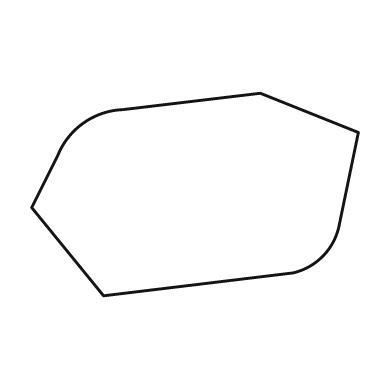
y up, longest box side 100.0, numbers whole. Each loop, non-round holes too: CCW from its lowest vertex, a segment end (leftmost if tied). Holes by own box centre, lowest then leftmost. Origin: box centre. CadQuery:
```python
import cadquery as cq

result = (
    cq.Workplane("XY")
    .moveTo(-28.0, -31.0)
    .lineTo(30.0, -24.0)
    .threePointArc((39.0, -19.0), (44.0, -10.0))
    .lineTo(50.0, 19.0)
    .lineTo(20.0, 31.0)
    .lineTo(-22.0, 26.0)
    .threePointArc((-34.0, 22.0), (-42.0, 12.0))
    .lineTo(-50.0, -4.0)
    .close()
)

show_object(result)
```